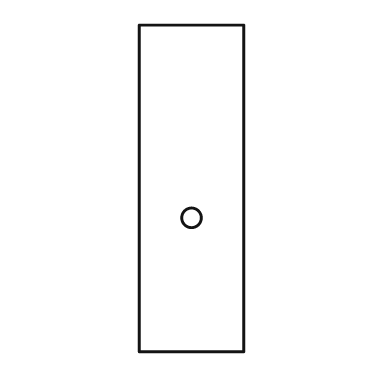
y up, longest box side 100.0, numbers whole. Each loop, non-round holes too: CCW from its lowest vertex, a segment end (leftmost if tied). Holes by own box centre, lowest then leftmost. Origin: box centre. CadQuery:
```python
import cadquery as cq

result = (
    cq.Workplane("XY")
    .moveTo(-16.0, -50.0)
    .lineTo(16.0, -50.0)
    .lineTo(16.0, 50.0)
    .lineTo(-16.0, 50.0)
    .close()
    .moveTo(0.0, -9.0)
    .circle(3.0)
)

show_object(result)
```